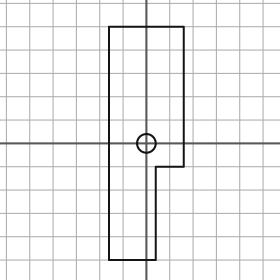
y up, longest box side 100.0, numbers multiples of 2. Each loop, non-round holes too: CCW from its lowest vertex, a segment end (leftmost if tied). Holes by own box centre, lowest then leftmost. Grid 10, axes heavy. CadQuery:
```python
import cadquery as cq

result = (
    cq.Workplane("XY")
    .moveTo(-16.0, -50.0)
    .lineTo(4.0, -50.0)
    .lineTo(4.0, -10.0)
    .lineTo(16.0, -10.0)
    .lineTo(16.0, 50.0)
    .lineTo(-16.0, 50.0)
    .close()
    .moveTo(0.0, 0.0)
    .circle(4.0)
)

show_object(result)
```